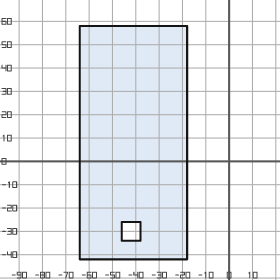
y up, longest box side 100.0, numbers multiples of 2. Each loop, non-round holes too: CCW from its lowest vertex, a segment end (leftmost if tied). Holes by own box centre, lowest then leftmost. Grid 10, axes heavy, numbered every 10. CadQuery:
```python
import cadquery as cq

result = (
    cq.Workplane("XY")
    .moveTo(-64.0, -42.0)
    .lineTo(-18.0, -42.0)
    .lineTo(-18.0, 58.0)
    .lineTo(-64.0, 58.0)
    .close()
    .moveTo(-46.0, -34.0)
    .lineTo(-38.0, -34.0)
    .lineTo(-38.0, -26.0)
    .lineTo(-46.0, -26.0)
    .close()
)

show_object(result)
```